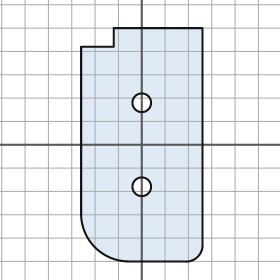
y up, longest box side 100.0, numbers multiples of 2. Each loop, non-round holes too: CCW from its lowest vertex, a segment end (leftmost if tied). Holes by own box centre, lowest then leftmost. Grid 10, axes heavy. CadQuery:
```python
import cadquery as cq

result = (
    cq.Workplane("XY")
    .moveTo(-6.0, -50.0)
    .lineTo(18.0, -50.0)
    .threePointArc((24.0, -48.0), (26.0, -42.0))
    .lineTo(26.0, 50.0)
    .lineTo(-12.0, 50.0)
    .lineTo(-12.0, 42.0)
    .lineTo(-26.0, 42.0)
    .lineTo(-26.0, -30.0)
    .threePointArc((-20.0, -44.0), (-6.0, -50.0))
    .close()
    .moveTo(0.0, -18.0)
    .circle(4.0)
    .moveTo(0.0, 18.0)
    .circle(4.0)
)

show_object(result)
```